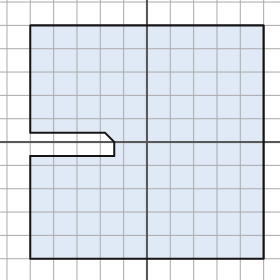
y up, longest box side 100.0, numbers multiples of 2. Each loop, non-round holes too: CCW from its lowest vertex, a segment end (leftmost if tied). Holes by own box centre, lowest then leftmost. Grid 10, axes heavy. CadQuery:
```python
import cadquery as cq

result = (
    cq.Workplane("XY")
    .moveTo(-50.0, -50.0)
    .lineTo(50.0, -50.0)
    .lineTo(50.0, 50.0)
    .lineTo(-50.0, 50.0)
    .lineTo(-50.0, 4.0)
    .lineTo(-18.0, 4.0)
    .lineTo(-14.0, 0.0)
    .lineTo(-14.0, -6.0)
    .lineTo(-50.0, -6.0)
    .close()
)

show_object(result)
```